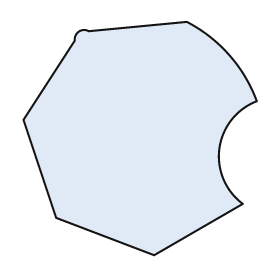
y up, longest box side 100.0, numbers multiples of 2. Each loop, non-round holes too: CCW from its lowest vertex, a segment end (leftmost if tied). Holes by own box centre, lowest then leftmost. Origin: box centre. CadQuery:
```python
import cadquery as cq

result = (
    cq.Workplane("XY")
    .moveTo(6.0, -50.0)
    .lineTo(44.0, -28.0)
    .threePointArc((34.0, -4.0), (50.0, 16.0))
    .threePointArc((38.0, 36.0), (20.0, 50.0))
    .lineTo(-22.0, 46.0)
    .threePointArc((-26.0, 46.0), (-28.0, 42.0))
    .lineTo(-50.0, 8.0)
    .lineTo(-36.0, -34.0)
    .close()
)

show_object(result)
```